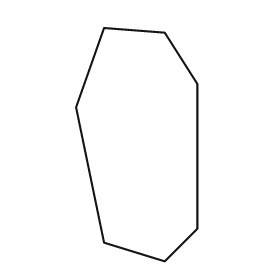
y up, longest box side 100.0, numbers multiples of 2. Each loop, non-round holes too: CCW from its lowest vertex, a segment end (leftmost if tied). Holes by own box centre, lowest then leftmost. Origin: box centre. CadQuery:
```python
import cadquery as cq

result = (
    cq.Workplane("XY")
    .moveTo(12.0, -50.0)
    .lineTo(26.0, -36.0)
    .lineTo(26.0, 26.0)
    .lineTo(12.0, 48.0)
    .lineTo(-14.0, 50.0)
    .lineTo(-26.0, 16.0)
    .lineTo(-14.0, -42.0)
    .close()
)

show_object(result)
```